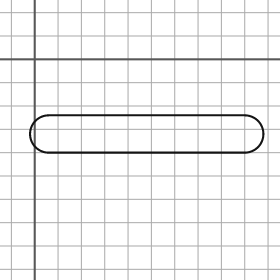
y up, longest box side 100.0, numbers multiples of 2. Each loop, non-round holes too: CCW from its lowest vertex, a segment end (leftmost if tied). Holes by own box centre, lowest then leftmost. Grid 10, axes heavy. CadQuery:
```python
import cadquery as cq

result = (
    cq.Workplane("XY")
    .moveTo(6.0, -40.0)
    .lineTo(90.0, -40.0)
    .threePointArc((98.0, -32.0), (90.0, -24.0))
    .lineTo(6.0, -24.0)
    .threePointArc((-2.0, -32.0), (6.0, -40.0))
    .close()
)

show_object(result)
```